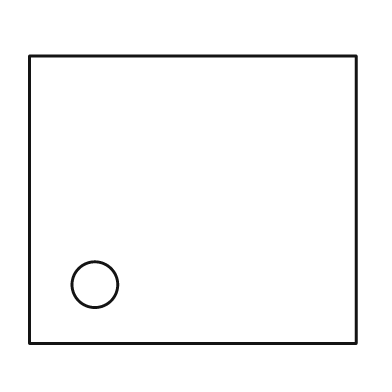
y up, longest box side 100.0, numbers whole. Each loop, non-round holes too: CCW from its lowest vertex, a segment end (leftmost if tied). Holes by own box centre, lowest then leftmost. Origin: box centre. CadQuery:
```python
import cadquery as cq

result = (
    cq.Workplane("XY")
    .moveTo(-50.0, -44.0)
    .lineTo(50.0, -44.0)
    .lineTo(50.0, 44.0)
    .lineTo(-50.0, 44.0)
    .close()
    .moveTo(-30.0, -26.0)
    .circle(7.0)
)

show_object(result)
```